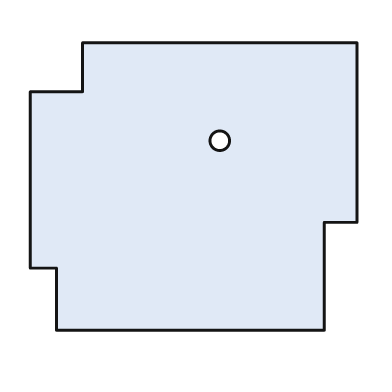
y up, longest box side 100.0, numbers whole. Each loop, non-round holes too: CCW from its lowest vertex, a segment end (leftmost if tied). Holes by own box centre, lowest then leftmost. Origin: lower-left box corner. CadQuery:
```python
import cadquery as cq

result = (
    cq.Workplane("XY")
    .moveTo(8.0, 0.0)
    .lineTo(90.0, 0.0)
    .lineTo(90.0, 33.0)
    .lineTo(100.0, 33.0)
    .lineTo(100.0, 88.0)
    .lineTo(16.0, 88.0)
    .lineTo(16.0, 73.0)
    .lineTo(0.0, 73.0)
    .lineTo(0.0, 19.0)
    .lineTo(8.0, 19.0)
    .close()
    .moveTo(58.0, 58.0)
    .circle(3.0)
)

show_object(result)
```